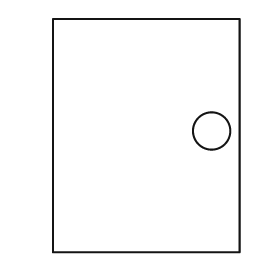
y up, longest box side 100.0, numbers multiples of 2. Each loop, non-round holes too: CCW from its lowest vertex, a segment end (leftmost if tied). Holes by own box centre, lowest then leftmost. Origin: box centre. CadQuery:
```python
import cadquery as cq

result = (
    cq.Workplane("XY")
    .moveTo(-40.0, -50.0)
    .lineTo(40.0, -50.0)
    .lineTo(40.0, 50.0)
    .lineTo(-40.0, 50.0)
    .close()
    .moveTo(28.0, 2.0)
    .circle(8.0)
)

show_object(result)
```